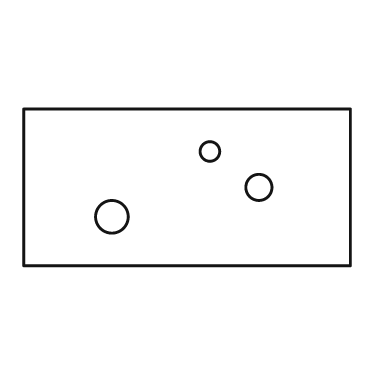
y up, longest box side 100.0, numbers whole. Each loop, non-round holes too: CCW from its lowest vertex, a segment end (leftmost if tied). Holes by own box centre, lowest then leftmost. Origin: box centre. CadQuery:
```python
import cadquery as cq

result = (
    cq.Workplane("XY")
    .moveTo(-50.0, -24.0)
    .lineTo(50.0, -24.0)
    .lineTo(50.0, 24.0)
    .lineTo(-50.0, 24.0)
    .close()
    .moveTo(-23.0, -9.0)
    .circle(5.0)
    .moveTo(22.0, 0.0)
    .circle(4.0)
    .moveTo(7.0, 11.0)
    .circle(3.0)
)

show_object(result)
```